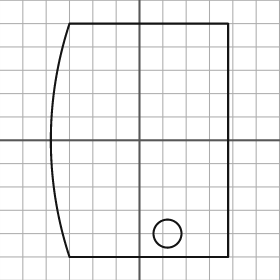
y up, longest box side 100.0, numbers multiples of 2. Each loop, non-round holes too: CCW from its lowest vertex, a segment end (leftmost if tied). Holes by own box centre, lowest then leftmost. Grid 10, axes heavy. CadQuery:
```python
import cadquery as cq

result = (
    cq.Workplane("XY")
    .moveTo(-30.0, -50.0)
    .lineTo(38.0, -50.0)
    .lineTo(38.0, 50.0)
    .lineTo(-30.0, 50.0)
    .threePointArc((-38.0, 0.0), (-30.0, -50.0))
    .close()
    .moveTo(12.0, -40.0)
    .circle(6.0)
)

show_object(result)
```